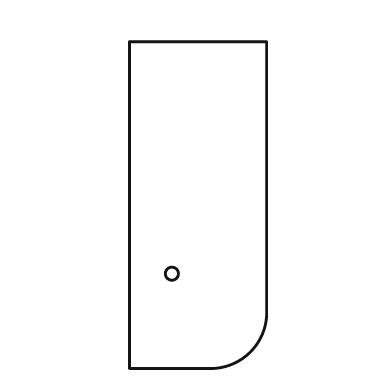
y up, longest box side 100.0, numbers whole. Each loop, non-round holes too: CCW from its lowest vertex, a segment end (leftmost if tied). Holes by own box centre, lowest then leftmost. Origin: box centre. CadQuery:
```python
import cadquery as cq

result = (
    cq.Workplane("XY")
    .moveTo(-21.0, -50.0)
    .lineTo(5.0, -50.0)
    .threePointArc((16.0, -45.0), (21.0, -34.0))
    .lineTo(21.0, 50.0)
    .lineTo(-21.0, 50.0)
    .close()
    .moveTo(-8.0, -21.0)
    .circle(2.0)
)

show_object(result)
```